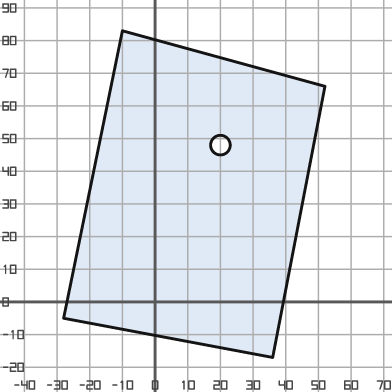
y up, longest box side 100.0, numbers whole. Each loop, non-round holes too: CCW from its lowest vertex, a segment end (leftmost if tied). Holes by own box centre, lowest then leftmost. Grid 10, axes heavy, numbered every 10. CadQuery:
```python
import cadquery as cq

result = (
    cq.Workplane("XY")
    .moveTo(36.0, -17.0)
    .lineTo(52.0, 66.0)
    .lineTo(-10.0, 83.0)
    .lineTo(-28.0, -5.0)
    .close()
    .moveTo(20.0, 48.0)
    .circle(3.0)
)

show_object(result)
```